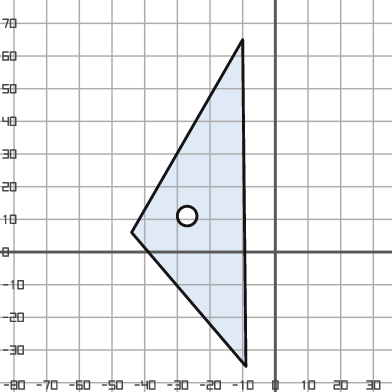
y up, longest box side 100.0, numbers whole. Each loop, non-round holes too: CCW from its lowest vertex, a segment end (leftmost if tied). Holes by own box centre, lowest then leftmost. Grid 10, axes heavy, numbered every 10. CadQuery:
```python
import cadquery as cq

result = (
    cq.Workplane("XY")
    .moveTo(-9.0, -35.0)
    .lineTo(-10.0, 65.0)
    .lineTo(-44.0, 6.0)
    .close()
    .moveTo(-27.0, 11.0)
    .circle(3.0)
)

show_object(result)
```